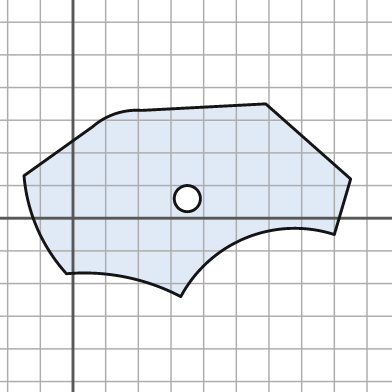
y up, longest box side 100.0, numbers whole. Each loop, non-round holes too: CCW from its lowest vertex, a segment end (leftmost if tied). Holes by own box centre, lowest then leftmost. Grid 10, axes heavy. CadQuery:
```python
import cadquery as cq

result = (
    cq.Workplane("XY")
    .moveTo(33.0, -24.0)
    .threePointArc((53.0, -6.0), (80.0, -5.0))
    .lineTo(85.0, 12.0)
    .lineTo(59.0, 35.0)
    .lineTo(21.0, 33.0)
    .threePointArc((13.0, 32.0), (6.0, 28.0))
    .lineTo(-15.0, 13.0)
    .threePointArc((-11.0, -3.0), (-2.0, -17.0))
    .threePointArc((16.0, -18.0), (33.0, -24.0))
    .close()
    .moveTo(35.0, 6.0)
    .circle(4.0)
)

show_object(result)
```